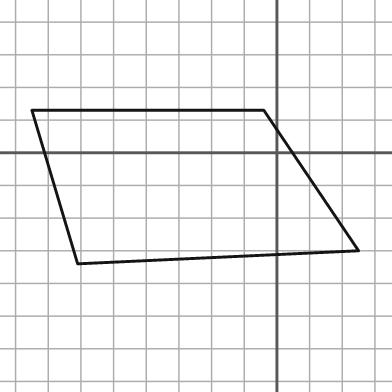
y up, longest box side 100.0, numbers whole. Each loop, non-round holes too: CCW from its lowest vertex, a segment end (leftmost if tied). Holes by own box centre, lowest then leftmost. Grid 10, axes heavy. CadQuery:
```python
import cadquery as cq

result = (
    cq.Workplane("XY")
    .moveTo(-61.0, -34.0)
    .lineTo(25.0, -30.0)
    .lineTo(-4.0, 13.0)
    .lineTo(-75.0, 13.0)
    .close()
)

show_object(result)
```